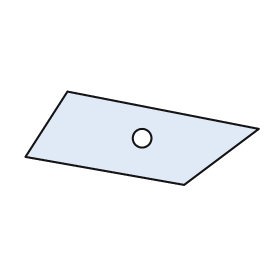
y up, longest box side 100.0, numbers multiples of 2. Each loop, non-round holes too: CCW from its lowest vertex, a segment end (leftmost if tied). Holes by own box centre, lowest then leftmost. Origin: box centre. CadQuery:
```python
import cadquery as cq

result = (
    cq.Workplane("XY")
    .moveTo(18.0, -20.0)
    .lineTo(50.0, 4.0)
    .lineTo(-32.0, 20.0)
    .lineTo(-50.0, -8.0)
    .close()
    .moveTo(0.0, 0.0)
    .circle(4.0)
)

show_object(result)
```